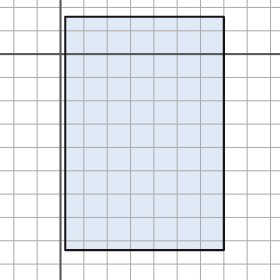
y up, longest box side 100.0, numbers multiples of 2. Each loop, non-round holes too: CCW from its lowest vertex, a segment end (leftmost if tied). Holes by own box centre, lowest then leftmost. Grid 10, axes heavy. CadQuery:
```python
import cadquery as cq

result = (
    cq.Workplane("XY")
    .moveTo(2.0, -84.0)
    .lineTo(70.0, -84.0)
    .lineTo(70.0, 16.0)
    .lineTo(2.0, 16.0)
    .close()
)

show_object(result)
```